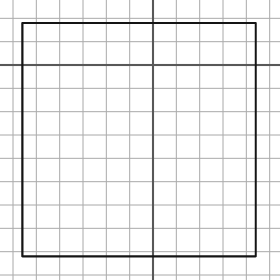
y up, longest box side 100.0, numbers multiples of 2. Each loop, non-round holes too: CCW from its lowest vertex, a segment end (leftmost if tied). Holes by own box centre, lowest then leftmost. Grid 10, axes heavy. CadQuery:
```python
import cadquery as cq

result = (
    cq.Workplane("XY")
    .moveTo(-56.0, -82.0)
    .lineTo(44.0, -82.0)
    .lineTo(44.0, 18.0)
    .lineTo(-56.0, 18.0)
    .close()
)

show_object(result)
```